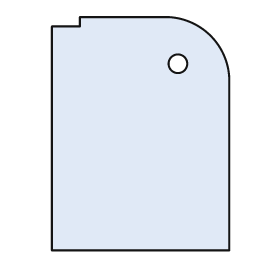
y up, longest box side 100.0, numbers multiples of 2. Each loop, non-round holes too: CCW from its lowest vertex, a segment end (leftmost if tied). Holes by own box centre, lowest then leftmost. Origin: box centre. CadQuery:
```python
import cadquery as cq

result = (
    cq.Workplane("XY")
    .moveTo(-38.0, -50.0)
    .lineTo(38.0, -50.0)
    .lineTo(38.0, 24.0)
    .threePointArc((30.0, 42.0), (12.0, 50.0))
    .lineTo(-26.0, 50.0)
    .lineTo(-26.0, 46.0)
    .lineTo(-38.0, 46.0)
    .close()
    .moveTo(16.0, 30.0)
    .circle(4.0)
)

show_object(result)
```